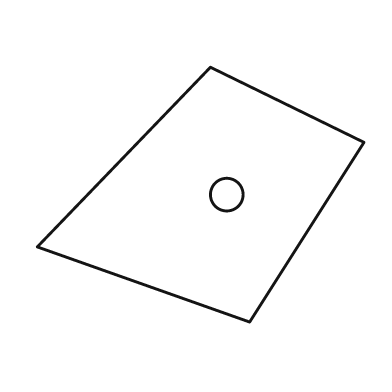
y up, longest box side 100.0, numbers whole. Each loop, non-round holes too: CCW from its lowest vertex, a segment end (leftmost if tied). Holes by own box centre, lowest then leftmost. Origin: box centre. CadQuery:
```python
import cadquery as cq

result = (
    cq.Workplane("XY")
    .moveTo(15.0, -39.0)
    .lineTo(50.0, 16.0)
    .lineTo(3.0, 39.0)
    .lineTo(-50.0, -16.0)
    .close()
    .moveTo(8.0, 0.0)
    .circle(5.0)
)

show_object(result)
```